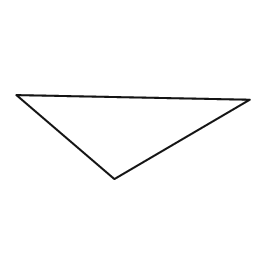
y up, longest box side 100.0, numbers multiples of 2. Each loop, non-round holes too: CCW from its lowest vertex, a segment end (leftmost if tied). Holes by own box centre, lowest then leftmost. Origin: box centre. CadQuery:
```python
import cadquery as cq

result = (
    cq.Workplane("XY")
    .moveTo(-8.0, -18.0)
    .lineTo(50.0, 16.0)
    .lineTo(-50.0, 18.0)
    .close()
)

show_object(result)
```